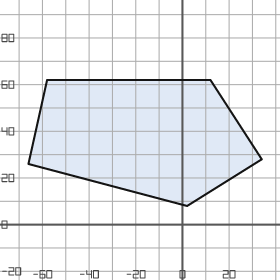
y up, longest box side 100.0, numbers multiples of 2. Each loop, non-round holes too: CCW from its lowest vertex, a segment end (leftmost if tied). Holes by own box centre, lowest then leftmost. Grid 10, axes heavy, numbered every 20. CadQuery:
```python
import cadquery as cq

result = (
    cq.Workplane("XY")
    .moveTo(2.0, 8.0)
    .lineTo(34.0, 28.0)
    .lineTo(12.0, 62.0)
    .lineTo(-58.0, 62.0)
    .lineTo(-66.0, 26.0)
    .close()
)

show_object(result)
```